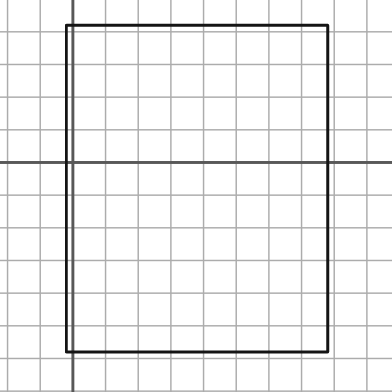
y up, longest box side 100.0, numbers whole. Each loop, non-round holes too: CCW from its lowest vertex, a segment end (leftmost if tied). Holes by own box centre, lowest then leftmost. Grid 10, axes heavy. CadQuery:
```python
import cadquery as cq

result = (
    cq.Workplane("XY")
    .moveTo(-2.0, -58.0)
    .lineTo(78.0, -58.0)
    .lineTo(78.0, 42.0)
    .lineTo(-2.0, 42.0)
    .close()
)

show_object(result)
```